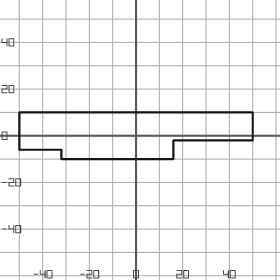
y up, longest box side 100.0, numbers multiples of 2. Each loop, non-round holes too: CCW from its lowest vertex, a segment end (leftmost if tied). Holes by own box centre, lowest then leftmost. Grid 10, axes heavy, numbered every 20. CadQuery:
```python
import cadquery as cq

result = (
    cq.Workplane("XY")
    .moveTo(-32.0, -10.0)
    .lineTo(16.0, -10.0)
    .lineTo(16.0, -2.0)
    .lineTo(50.0, -2.0)
    .lineTo(50.0, 10.0)
    .lineTo(-50.0, 10.0)
    .lineTo(-50.0, -6.0)
    .lineTo(-32.0, -6.0)
    .close()
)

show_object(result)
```